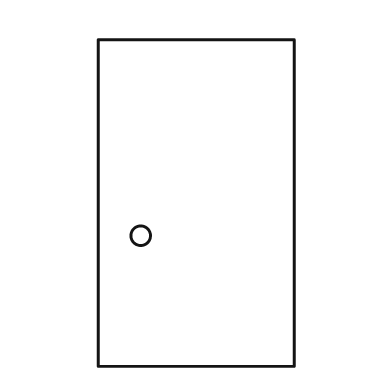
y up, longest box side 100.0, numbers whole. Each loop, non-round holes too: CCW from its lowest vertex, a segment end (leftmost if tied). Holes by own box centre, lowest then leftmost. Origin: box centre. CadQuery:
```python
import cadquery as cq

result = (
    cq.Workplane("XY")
    .moveTo(-30.0, -50.0)
    .lineTo(30.0, -50.0)
    .lineTo(30.0, 50.0)
    .lineTo(-30.0, 50.0)
    .close()
    .moveTo(-17.0, -10.0)
    .circle(3.0)
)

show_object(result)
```